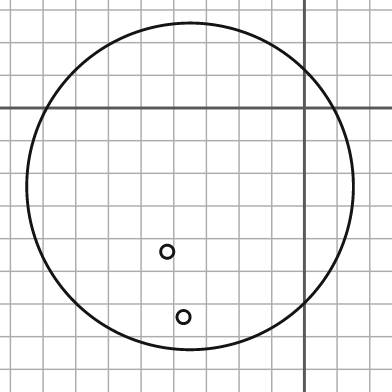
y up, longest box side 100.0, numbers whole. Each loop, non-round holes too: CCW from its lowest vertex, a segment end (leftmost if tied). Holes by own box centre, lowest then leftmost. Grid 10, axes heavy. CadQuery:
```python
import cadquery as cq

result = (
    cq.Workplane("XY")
    .moveTo(-35.0, -24.0)
    .circle(50.0)
    .moveTo(-37.0, -64.0)
    .circle(2.0)
    .moveTo(-42.0, -44.0)
    .circle(2.0)
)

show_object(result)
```